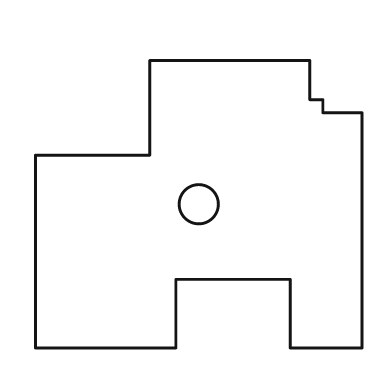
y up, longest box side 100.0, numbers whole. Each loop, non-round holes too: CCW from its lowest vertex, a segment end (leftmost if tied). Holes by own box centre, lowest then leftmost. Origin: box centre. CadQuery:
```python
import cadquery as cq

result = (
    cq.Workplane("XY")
    .moveTo(-50.0, -44.0)
    .lineTo(-7.0, -44.0)
    .lineTo(-7.0, -23.0)
    .lineTo(28.0, -23.0)
    .lineTo(28.0, -44.0)
    .lineTo(50.0, -44.0)
    .lineTo(50.0, 28.0)
    .lineTo(38.0, 28.0)
    .lineTo(38.0, 32.0)
    .lineTo(34.0, 32.0)
    .lineTo(34.0, 44.0)
    .lineTo(-15.0, 44.0)
    .lineTo(-15.0, 15.0)
    .lineTo(-50.0, 15.0)
    .close()
    .moveTo(0.0, 0.0)
    .circle(6.0)
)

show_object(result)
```